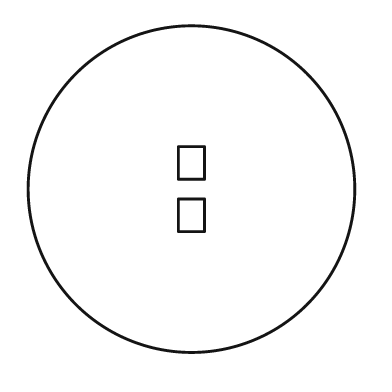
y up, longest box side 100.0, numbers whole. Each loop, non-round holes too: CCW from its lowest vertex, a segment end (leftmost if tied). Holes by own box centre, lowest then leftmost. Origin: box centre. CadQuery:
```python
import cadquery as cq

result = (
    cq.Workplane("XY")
    .moveTo(0.0, 0.0)
    .circle(50.0)
    .moveTo(-4.0, -13.0)
    .lineTo(4.0, -13.0)
    .lineTo(4.0, -3.0)
    .lineTo(-4.0, -3.0)
    .close()
    .moveTo(-4.0, 3.0)
    .lineTo(4.0, 3.0)
    .lineTo(4.0, 13.0)
    .lineTo(-4.0, 13.0)
    .close()
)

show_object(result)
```